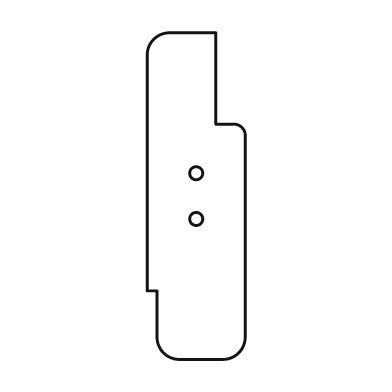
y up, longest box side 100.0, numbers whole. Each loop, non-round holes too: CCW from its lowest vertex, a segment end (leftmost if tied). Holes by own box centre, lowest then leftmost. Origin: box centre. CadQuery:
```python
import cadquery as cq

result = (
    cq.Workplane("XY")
    .moveTo(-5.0, -50.0)
    .lineTo(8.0, -50.0)
    .threePointArc((13.0, -48.0), (15.0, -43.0))
    .lineTo(15.0, 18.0)
    .threePointArc((14.0, 21.0), (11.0, 22.0))
    .lineTo(6.0, 22.0)
    .lineTo(6.0, 50.0)
    .lineTo(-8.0, 50.0)
    .threePointArc((-13.0, 48.0), (-15.0, 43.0))
    .lineTo(-15.0, -29.0)
    .lineTo(-12.0, -29.0)
    .lineTo(-12.0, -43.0)
    .threePointArc((-10.0, -48.0), (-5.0, -50.0))
    .close()
    .moveTo(0.0, -7.0)
    .circle(2.0)
    .moveTo(0.0, 7.0)
    .circle(2.0)
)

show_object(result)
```